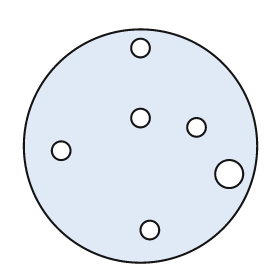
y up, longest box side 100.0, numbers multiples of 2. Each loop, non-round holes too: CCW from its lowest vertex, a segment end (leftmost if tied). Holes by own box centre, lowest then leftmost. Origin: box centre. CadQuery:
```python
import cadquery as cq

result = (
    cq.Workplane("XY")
    .moveTo(0.0, 0.0)
    .circle(50.0)
    .moveTo(4.0, -36.0)
    .circle(4.0)
    .moveTo(38.0, -12.0)
    .circle(6.0)
    .moveTo(-34.0, -2.0)
    .circle(4.0)
    .moveTo(24.0, 8.0)
    .circle(4.0)
    .moveTo(0.0, 12.0)
    .circle(4.0)
    .moveTo(0.0, 42.0)
    .circle(4.0)
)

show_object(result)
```